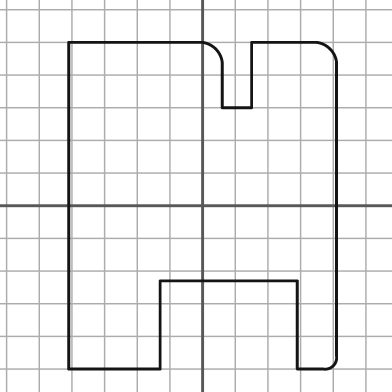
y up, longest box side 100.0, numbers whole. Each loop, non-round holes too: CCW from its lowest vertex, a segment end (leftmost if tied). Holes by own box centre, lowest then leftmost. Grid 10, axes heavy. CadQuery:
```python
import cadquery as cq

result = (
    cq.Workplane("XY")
    .moveTo(-41.0, -50.0)
    .lineTo(-13.0, -50.0)
    .lineTo(-13.0, -23.0)
    .lineTo(29.0, -23.0)
    .lineTo(29.0, -50.0)
    .lineTo(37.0, -50.0)
    .threePointArc((40.0, -49.0), (41.0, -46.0))
    .lineTo(41.0, 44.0)
    .threePointArc((39.0, 48.0), (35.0, 50.0))
    .lineTo(15.0, 50.0)
    .lineTo(15.0, 30.0)
    .lineTo(6.0, 30.0)
    .lineTo(6.0, 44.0)
    .threePointArc((4.0, 48.0), (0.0, 50.0))
    .lineTo(-41.0, 50.0)
    .close()
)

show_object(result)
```